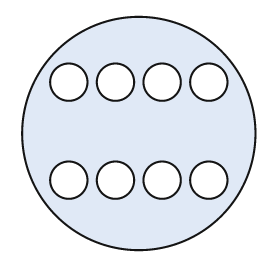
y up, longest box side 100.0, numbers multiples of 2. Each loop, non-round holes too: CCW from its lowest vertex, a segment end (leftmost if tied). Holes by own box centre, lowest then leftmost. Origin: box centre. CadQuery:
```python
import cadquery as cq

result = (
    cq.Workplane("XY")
    .moveTo(0.0, 0.0)
    .circle(50.0)
    .moveTo(-30.0, -20.0)
    .circle(8.0)
    .moveTo(-10.0, -20.0)
    .circle(8.0)
    .moveTo(10.0, -20.0)
    .circle(8.0)
    .moveTo(30.0, -20.0)
    .circle(8.0)
    .moveTo(-30.0, 22.0)
    .circle(8.0)
    .moveTo(-10.0, 22.0)
    .circle(8.0)
    .moveTo(10.0, 22.0)
    .circle(8.0)
    .moveTo(30.0, 22.0)
    .circle(8.0)
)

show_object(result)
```